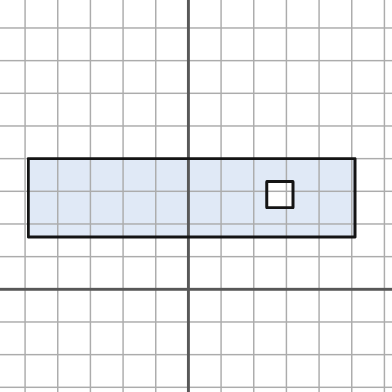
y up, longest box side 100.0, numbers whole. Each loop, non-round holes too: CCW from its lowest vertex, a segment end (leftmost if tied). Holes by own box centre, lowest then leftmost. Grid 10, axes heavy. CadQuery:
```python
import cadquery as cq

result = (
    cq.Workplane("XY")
    .moveTo(-49.0, 16.0)
    .lineTo(51.0, 16.0)
    .lineTo(51.0, 40.0)
    .lineTo(-49.0, 40.0)
    .close()
    .moveTo(24.0, 25.0)
    .lineTo(32.0, 25.0)
    .lineTo(32.0, 33.0)
    .lineTo(24.0, 33.0)
    .close()
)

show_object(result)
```